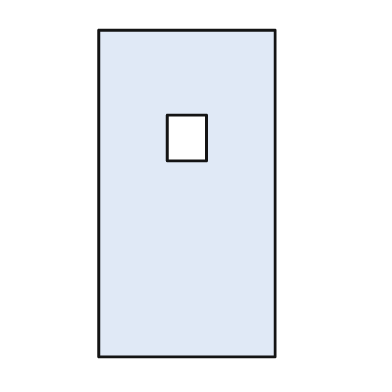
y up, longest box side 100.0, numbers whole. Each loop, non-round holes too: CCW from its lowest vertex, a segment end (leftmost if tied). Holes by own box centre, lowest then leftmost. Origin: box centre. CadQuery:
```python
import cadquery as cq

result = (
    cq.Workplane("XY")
    .moveTo(-27.0, -50.0)
    .lineTo(27.0, -50.0)
    .lineTo(27.0, 50.0)
    .lineTo(-27.0, 50.0)
    .close()
    .moveTo(-6.0, 10.0)
    .lineTo(6.0, 10.0)
    .lineTo(6.0, 24.0)
    .lineTo(-6.0, 24.0)
    .close()
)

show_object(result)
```